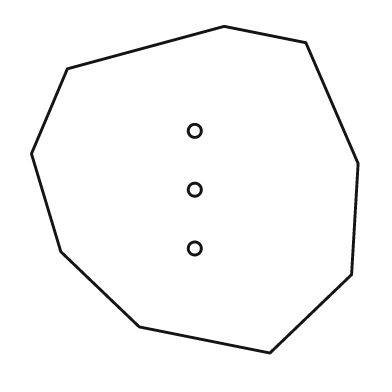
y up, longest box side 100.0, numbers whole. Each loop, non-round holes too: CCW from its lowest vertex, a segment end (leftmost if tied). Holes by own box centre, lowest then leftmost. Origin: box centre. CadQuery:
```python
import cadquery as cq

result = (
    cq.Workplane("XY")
    .moveTo(23.0, -50.0)
    .lineTo(48.0, -26.0)
    .lineTo(50.0, 8.0)
    .lineTo(34.0, 45.0)
    .lineTo(9.0, 50.0)
    .lineTo(-39.0, 37.0)
    .lineTo(-50.0, 11.0)
    .lineTo(-41.0, -19.0)
    .lineTo(-17.0, -42.0)
    .close()
    .moveTo(0.0, -18.0)
    .circle(2.0)
    .moveTo(0.0, 0.0)
    .circle(2.0)
    .moveTo(0.0, 18.0)
    .circle(2.0)
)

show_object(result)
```